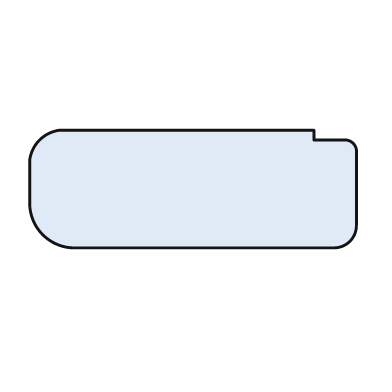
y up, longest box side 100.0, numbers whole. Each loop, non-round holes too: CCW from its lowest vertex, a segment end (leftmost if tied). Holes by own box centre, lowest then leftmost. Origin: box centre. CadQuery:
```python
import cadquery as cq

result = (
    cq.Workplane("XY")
    .moveTo(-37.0, -18.0)
    .lineTo(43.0, -18.0)
    .threePointArc((48.0, -16.0), (50.0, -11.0))
    .lineTo(50.0, 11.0)
    .threePointArc((49.0, 14.0), (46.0, 15.0))
    .lineTo(37.0, 15.0)
    .lineTo(37.0, 18.0)
    .lineTo(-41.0, 18.0)
    .threePointArc((-47.0, 15.0), (-50.0, 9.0))
    .lineTo(-50.0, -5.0)
    .threePointArc((-46.0, -14.0), (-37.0, -18.0))
    .close()
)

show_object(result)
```